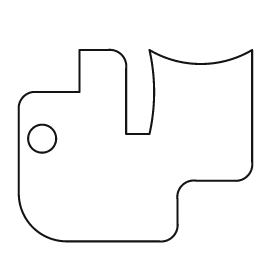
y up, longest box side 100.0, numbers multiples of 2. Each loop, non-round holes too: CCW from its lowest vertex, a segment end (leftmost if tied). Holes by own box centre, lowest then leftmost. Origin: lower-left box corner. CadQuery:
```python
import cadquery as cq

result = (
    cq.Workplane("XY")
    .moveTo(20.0, 0.0)
    .lineTo(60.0, 0.0)
    .threePointArc((66.0, 2.0), (68.0, 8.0))
    .lineTo(68.0, 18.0)
    .threePointArc((70.0, 24.0), (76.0, 26.0))
    .lineTo(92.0, 26.0)
    .threePointArc((98.0, 28.0), (100.0, 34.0))
    .lineTo(100.0, 82.0)
    .threePointArc((78.0, 76.0), (56.0, 82.0))
    .threePointArc((58.0, 64.0), (56.0, 46.0))
    .lineTo(46.0, 46.0)
    .lineTo(46.0, 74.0)
    .threePointArc((44.0, 80.0), (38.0, 82.0))
    .lineTo(26.0, 82.0)
    .lineTo(26.0, 64.0)
    .lineTo(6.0, 64.0)
    .threePointArc((2.0, 62.0), (0.0, 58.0))
    .lineTo(0.0, 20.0)
    .threePointArc((6.0, 6.0), (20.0, 0.0))
    .close()
    .moveTo(10.0, 44.0)
    .circle(6.0)
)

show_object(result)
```